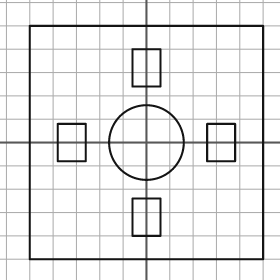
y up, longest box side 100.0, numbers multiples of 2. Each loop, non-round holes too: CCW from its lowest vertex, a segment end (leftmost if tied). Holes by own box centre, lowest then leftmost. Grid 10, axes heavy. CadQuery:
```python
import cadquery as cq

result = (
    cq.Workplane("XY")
    .moveTo(-50.0, -50.0)
    .lineTo(50.0, -50.0)
    .lineTo(50.0, 50.0)
    .lineTo(-50.0, 50.0)
    .close()
    .moveTo(-6.0, -40.0)
    .lineTo(6.0, -40.0)
    .lineTo(6.0, -24.0)
    .lineTo(-6.0, -24.0)
    .close()
    .moveTo(-38.0, -8.0)
    .lineTo(-26.0, -8.0)
    .lineTo(-26.0, 8.0)
    .lineTo(-38.0, 8.0)
    .close()
    .moveTo(0.0, 0.0)
    .circle(16.0)
    .moveTo(26.0, -8.0)
    .lineTo(38.0, -8.0)
    .lineTo(38.0, 8.0)
    .lineTo(26.0, 8.0)
    .close()
    .moveTo(-6.0, 24.0)
    .lineTo(6.0, 24.0)
    .lineTo(6.0, 40.0)
    .lineTo(-6.0, 40.0)
    .close()
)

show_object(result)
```